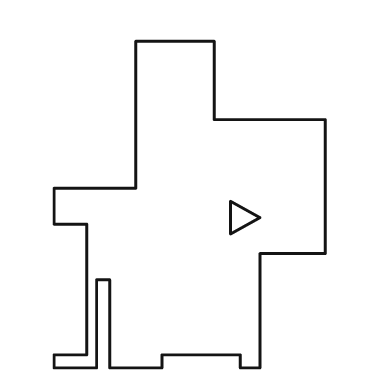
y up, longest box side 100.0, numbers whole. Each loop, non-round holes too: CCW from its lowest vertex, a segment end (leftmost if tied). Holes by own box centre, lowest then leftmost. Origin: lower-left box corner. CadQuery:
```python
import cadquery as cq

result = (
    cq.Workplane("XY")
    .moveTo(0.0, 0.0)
    .lineTo(13.0, 0.0)
    .lineTo(13.0, 27.0)
    .lineTo(17.0, 27.0)
    .lineTo(17.0, 0.0)
    .lineTo(33.0, 0.0)
    .lineTo(33.0, 4.0)
    .lineTo(57.0, 4.0)
    .lineTo(57.0, 0.0)
    .lineTo(63.0, 0.0)
    .lineTo(63.0, 35.0)
    .lineTo(83.0, 35.0)
    .lineTo(83.0, 76.0)
    .lineTo(49.0, 76.0)
    .lineTo(49.0, 100.0)
    .lineTo(25.0, 100.0)
    .lineTo(25.0, 55.0)
    .lineTo(0.0, 55.0)
    .lineTo(0.0, 44.0)
    .lineTo(10.0, 44.0)
    .lineTo(10.0, 4.0)
    .lineTo(0.0, 4.0)
    .close()
    .moveTo(54.0, 41.0)
    .lineTo(63.0, 46.0)
    .lineTo(54.0, 51.0)
    .close()
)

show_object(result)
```